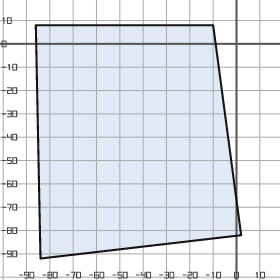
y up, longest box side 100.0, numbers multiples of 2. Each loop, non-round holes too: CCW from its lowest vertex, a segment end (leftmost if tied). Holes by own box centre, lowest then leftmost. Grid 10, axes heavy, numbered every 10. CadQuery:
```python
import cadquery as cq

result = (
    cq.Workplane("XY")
    .moveTo(-84.0, -92.0)
    .lineTo(2.0, -82.0)
    .lineTo(-10.0, 8.0)
    .lineTo(-86.0, 8.0)
    .close()
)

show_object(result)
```